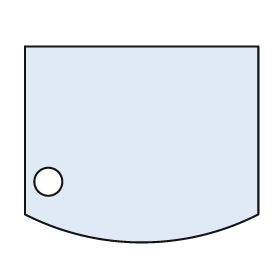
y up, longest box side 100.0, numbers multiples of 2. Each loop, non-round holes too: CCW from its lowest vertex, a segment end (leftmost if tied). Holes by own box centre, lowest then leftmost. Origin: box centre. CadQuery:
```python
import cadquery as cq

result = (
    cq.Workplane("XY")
    .moveTo(-50.0, -30.0)
    .threePointArc((0.0, -42.0), (50.0, -30.0))
    .lineTo(50.0, 42.0)
    .lineTo(-50.0, 42.0)
    .close()
    .moveTo(-40.0, -16.0)
    .circle(6.0)
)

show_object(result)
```